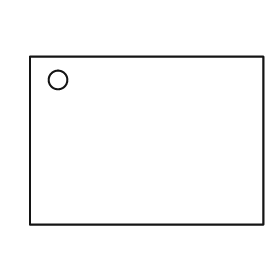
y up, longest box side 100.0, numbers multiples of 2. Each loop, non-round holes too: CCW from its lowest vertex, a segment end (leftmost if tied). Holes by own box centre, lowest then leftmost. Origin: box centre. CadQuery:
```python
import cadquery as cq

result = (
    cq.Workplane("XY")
    .moveTo(-50.0, -36.0)
    .lineTo(50.0, -36.0)
    .lineTo(50.0, 36.0)
    .lineTo(-50.0, 36.0)
    .close()
    .moveTo(-38.0, 26.0)
    .circle(4.0)
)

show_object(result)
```